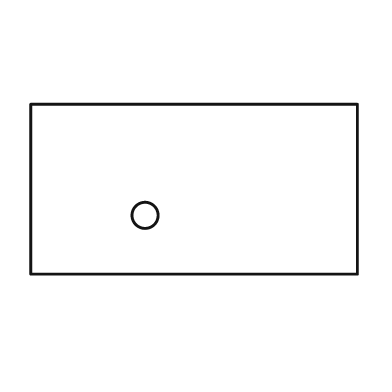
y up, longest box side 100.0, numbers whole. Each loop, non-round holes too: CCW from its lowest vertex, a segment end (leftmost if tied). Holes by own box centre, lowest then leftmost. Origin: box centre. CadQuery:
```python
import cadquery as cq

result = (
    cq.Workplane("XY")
    .moveTo(-50.0, -26.0)
    .lineTo(50.0, -26.0)
    .lineTo(50.0, 26.0)
    .lineTo(-50.0, 26.0)
    .close()
    .moveTo(-15.0, -8.0)
    .circle(4.0)
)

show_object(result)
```